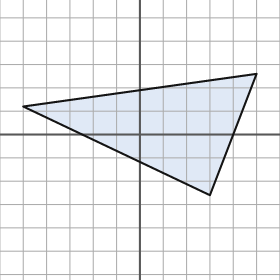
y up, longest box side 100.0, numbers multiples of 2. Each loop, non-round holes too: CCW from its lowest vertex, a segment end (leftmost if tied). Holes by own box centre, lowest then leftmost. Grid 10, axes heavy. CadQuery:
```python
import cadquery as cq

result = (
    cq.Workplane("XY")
    .moveTo(30.0, -26.0)
    .lineTo(50.0, 26.0)
    .lineTo(-50.0, 12.0)
    .close()
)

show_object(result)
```